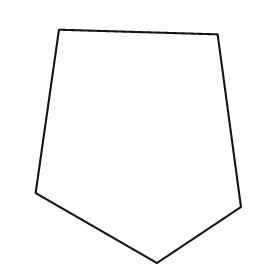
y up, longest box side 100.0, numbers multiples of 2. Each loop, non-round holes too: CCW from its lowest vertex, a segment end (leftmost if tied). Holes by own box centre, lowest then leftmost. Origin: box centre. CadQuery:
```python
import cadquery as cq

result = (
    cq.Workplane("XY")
    .moveTo(8.0, -50.0)
    .lineTo(44.0, -26.0)
    .lineTo(34.0, 48.0)
    .lineTo(-34.0, 50.0)
    .lineTo(-44.0, -20.0)
    .close()
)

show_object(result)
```